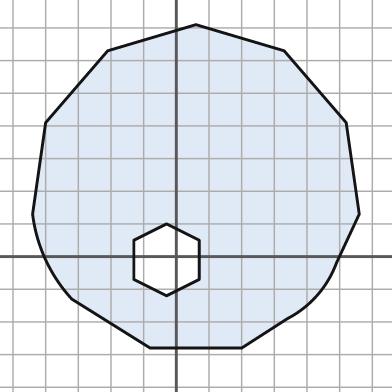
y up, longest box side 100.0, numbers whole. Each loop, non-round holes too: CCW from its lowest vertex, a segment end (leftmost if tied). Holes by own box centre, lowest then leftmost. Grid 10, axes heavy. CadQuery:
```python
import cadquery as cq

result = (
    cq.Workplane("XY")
    .moveTo(-8.0, -28.0)
    .lineTo(20.0, -28.0)
    .lineTo(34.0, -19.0)
    .threePointArc((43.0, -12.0), (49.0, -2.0))
    .lineTo(56.0, 13.0)
    .lineTo(52.0, 41.0)
    .lineTo(33.0, 63.0)
    .lineTo(6.0, 71.0)
    .lineTo(-21.0, 63.0)
    .lineTo(-40.0, 41.0)
    .lineTo(-44.0, 13.0)
    .threePointArc((-40.0, -1.0), (-32.0, -13.0))
    .close()
    .moveTo(-3.0, -12.0)
    .lineTo(7.0, -7.0)
    .lineTo(7.0, 5.0)
    .lineTo(-3.0, 10.0)
    .lineTo(-13.0, 5.0)
    .lineTo(-13.0, -7.0)
    .close()
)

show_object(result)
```